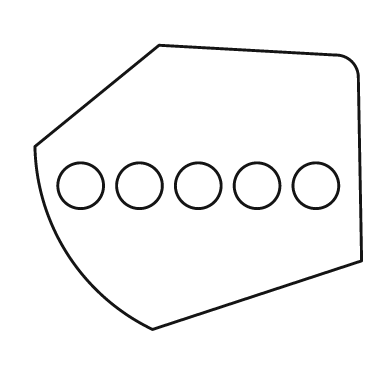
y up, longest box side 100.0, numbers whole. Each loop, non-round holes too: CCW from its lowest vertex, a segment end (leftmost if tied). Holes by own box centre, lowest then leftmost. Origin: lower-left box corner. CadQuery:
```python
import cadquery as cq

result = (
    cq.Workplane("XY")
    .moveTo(36.0, 0.0)
    .lineTo(100.0, 21.0)
    .lineTo(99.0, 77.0)
    .threePointArc((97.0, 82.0), (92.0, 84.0))
    .lineTo(38.0, 87.0)
    .lineTo(0.0, 56.0)
    .threePointArc((10.0, 23.0), (36.0, 0.0))
    .close()
    .moveTo(14.0, 44.0)
    .circle(7.0)
    .moveTo(32.0, 44.0)
    .circle(7.0)
    .moveTo(50.0, 44.0)
    .circle(7.0)
    .moveTo(68.0, 44.0)
    .circle(7.0)
    .moveTo(86.0, 44.0)
    .circle(7.0)
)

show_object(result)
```